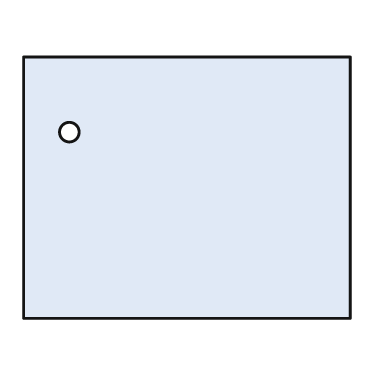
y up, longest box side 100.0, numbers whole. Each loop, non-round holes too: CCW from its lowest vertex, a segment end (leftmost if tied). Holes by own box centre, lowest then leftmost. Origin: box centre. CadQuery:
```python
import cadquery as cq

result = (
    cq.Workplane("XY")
    .moveTo(-50.0, -40.0)
    .lineTo(50.0, -40.0)
    .lineTo(50.0, 40.0)
    .lineTo(-50.0, 40.0)
    .close()
    .moveTo(-36.0, 17.0)
    .circle(3.0)
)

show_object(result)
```